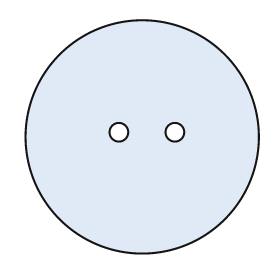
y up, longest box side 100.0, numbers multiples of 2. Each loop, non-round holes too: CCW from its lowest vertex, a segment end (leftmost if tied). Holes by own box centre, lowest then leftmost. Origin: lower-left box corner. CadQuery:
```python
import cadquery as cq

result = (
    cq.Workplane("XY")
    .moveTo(50.0, 50.0)
    .circle(50.0)
    .moveTo(40.0, 52.0)
    .circle(4.0)
    .moveTo(64.0, 52.0)
    .circle(4.0)
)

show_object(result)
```